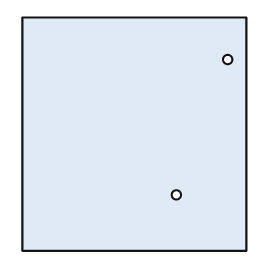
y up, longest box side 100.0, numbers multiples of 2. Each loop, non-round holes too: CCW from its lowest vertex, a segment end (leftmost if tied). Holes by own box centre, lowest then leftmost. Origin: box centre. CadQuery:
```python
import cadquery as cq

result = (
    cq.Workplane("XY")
    .moveTo(-48.0, -50.0)
    .lineTo(48.0, -50.0)
    .lineTo(48.0, 50.0)
    .lineTo(-48.0, 50.0)
    .close()
    .moveTo(18.0, -26.0)
    .circle(2.0)
    .moveTo(40.0, 32.0)
    .circle(2.0)
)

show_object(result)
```